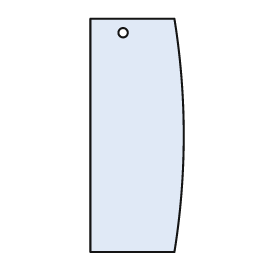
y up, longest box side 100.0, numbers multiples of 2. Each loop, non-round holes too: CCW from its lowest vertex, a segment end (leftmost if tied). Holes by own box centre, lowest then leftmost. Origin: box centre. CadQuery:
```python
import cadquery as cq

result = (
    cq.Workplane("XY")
    .moveTo(-20.0, -50.0)
    .lineTo(16.0, -50.0)
    .threePointArc((20.0, 0.0), (16.0, 50.0))
    .lineTo(-20.0, 50.0)
    .close()
    .moveTo(-6.0, 44.0)
    .circle(2.0)
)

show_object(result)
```